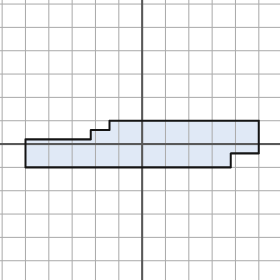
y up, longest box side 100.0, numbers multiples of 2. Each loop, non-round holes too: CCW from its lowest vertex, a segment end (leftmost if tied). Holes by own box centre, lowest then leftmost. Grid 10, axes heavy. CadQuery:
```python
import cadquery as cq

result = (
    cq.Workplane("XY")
    .moveTo(-50.0, -10.0)
    .lineTo(38.0, -10.0)
    .lineTo(38.0, -4.0)
    .lineTo(50.0, -4.0)
    .lineTo(50.0, 10.0)
    .lineTo(-14.0, 10.0)
    .lineTo(-14.0, 6.0)
    .lineTo(-22.0, 6.0)
    .lineTo(-22.0, 2.0)
    .lineTo(-50.0, 2.0)
    .close()
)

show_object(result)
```